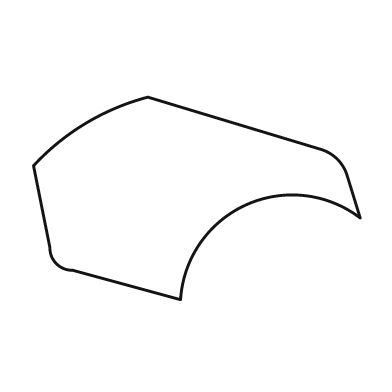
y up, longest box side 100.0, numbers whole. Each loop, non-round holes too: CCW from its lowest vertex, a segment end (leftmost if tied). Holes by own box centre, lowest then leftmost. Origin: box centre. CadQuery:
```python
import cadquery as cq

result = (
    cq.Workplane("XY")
    .moveTo(-5.0, -31.0)
    .threePointArc((15.0, -2.0), (50.0, -6.0))
    .lineTo(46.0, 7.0)
    .threePointArc((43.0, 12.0), (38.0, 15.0))
    .lineTo(-15.0, 31.0)
    .threePointArc((-34.0, 23.0), (-50.0, 10.0))
    .lineTo(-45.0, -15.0)
    .threePointArc((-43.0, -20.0), (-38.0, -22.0))
    .close()
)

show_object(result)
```